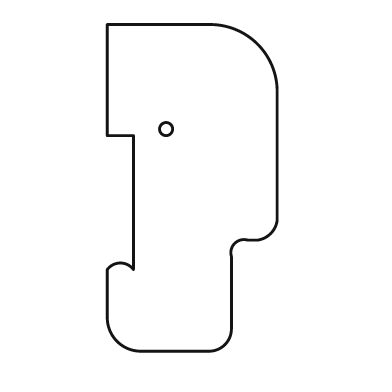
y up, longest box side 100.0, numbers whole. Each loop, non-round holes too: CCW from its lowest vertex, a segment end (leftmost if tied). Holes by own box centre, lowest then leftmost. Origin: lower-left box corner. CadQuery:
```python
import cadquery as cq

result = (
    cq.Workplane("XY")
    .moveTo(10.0, 0.0)
    .lineTo(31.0, 0.0)
    .threePointArc((36.0, 2.0), (38.0, 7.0))
    .lineTo(38.0, 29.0)
    .threePointArc((39.0, 33.0), (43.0, 34.0))
    .lineTo(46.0, 34.0)
    .threePointArc((50.0, 36.0), (52.0, 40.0))
    .lineTo(52.0, 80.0)
    .threePointArc((46.0, 94.0), (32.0, 100.0))
    .lineTo(0.0, 100.0)
    .lineTo(0.0, 66.0)
    .lineTo(8.0, 66.0)
    .lineTo(8.0, 25.0)
    .threePointArc((4.0, 27.0), (0.0, 25.0))
    .lineTo(0.0, 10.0)
    .threePointArc((3.0, 3.0), (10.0, 0.0))
    .close()
    .moveTo(18.0, 68.0)
    .circle(2.0)
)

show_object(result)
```